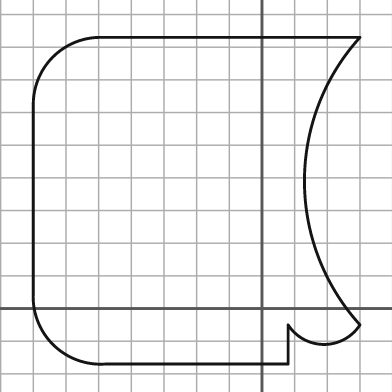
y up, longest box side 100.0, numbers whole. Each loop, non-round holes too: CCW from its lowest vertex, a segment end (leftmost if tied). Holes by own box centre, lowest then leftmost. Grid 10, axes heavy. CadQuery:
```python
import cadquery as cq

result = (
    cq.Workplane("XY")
    .moveTo(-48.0, -17.0)
    .lineTo(8.0, -17.0)
    .lineTo(8.0, -5.0)
    .threePointArc((19.0, -11.0), (30.0, -5.0))
    .threePointArc((13.0, 39.0), (30.0, 83.0))
    .lineTo(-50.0, 83.0)
    .threePointArc((-64.0, 77.0), (-70.0, 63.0))
    .lineTo(-70.0, 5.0)
    .threePointArc((-64.0, -11.0), (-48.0, -17.0))
    .close()
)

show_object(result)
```